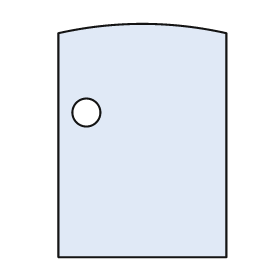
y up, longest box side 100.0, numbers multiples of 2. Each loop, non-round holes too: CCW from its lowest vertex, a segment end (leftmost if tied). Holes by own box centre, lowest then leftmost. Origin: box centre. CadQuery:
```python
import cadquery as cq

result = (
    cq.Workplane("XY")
    .moveTo(-36.0, -50.0)
    .lineTo(36.0, -50.0)
    .lineTo(36.0, 46.0)
    .threePointArc((0.0, 50.0), (-36.0, 46.0))
    .close()
    .moveTo(-24.0, 12.0)
    .circle(6.0)
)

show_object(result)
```